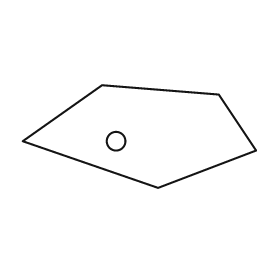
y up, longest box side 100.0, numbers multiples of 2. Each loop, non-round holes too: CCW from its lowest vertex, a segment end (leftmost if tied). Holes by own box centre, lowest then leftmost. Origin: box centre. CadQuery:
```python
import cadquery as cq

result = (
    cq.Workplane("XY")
    .moveTo(8.0, -22.0)
    .lineTo(50.0, -6.0)
    .lineTo(34.0, 18.0)
    .lineTo(-16.0, 22.0)
    .lineTo(-50.0, -2.0)
    .close()
    .moveTo(-10.0, -2.0)
    .circle(4.0)
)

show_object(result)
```